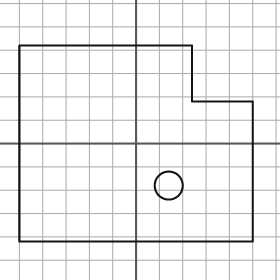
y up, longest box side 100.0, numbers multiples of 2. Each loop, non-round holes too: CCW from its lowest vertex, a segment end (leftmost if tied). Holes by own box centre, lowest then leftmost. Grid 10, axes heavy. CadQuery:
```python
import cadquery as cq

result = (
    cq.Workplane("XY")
    .moveTo(-50.0, -42.0)
    .lineTo(50.0, -42.0)
    .lineTo(50.0, 18.0)
    .lineTo(24.0, 18.0)
    .lineTo(24.0, 42.0)
    .lineTo(-50.0, 42.0)
    .close()
    .moveTo(14.0, -18.0)
    .circle(6.0)
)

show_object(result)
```